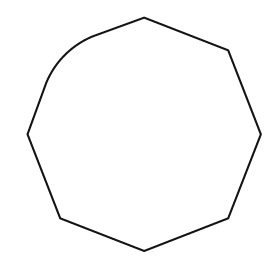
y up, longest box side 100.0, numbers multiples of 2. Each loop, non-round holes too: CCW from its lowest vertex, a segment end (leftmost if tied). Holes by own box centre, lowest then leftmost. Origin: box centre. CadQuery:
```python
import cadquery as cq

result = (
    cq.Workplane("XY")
    .moveTo(0.0, -50.0)
    .lineTo(36.0, -36.0)
    .lineTo(50.0, 0.0)
    .lineTo(36.0, 36.0)
    .lineTo(0.0, 50.0)
    .lineTo(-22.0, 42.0)
    .threePointArc((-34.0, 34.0), (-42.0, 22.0))
    .lineTo(-50.0, 0.0)
    .lineTo(-36.0, -36.0)
    .close()
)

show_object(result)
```